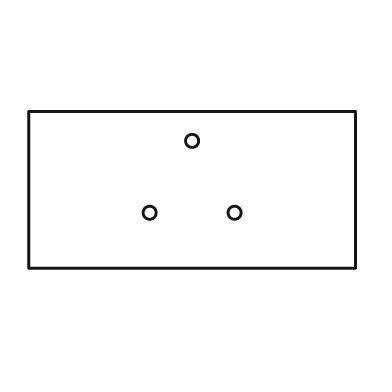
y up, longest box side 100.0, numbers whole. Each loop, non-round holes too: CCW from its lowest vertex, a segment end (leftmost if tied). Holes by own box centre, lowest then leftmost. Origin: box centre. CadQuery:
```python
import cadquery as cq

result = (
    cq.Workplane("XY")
    .moveTo(-50.0, -24.0)
    .lineTo(50.0, -24.0)
    .lineTo(50.0, 24.0)
    .lineTo(-50.0, 24.0)
    .close()
    .moveTo(-13.0, -7.0)
    .circle(2.0)
    .moveTo(13.0, -7.0)
    .circle(2.0)
    .moveTo(0.0, 15.0)
    .circle(2.0)
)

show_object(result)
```